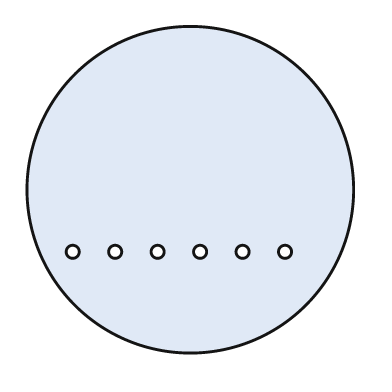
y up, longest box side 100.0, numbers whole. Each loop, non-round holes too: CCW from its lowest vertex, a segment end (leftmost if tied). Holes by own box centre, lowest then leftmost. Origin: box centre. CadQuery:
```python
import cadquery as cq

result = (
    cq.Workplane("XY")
    .moveTo(0.0, 0.0)
    .circle(50.0)
    .moveTo(-36.0, -19.0)
    .circle(2.0)
    .moveTo(-23.0, -19.0)
    .circle(2.0)
    .moveTo(-10.0, -19.0)
    .circle(2.0)
    .moveTo(3.0, -19.0)
    .circle(2.0)
    .moveTo(16.0, -19.0)
    .circle(2.0)
    .moveTo(29.0, -19.0)
    .circle(2.0)
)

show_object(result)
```